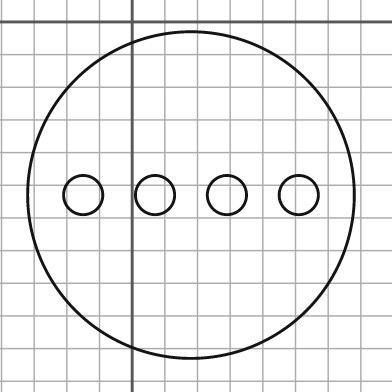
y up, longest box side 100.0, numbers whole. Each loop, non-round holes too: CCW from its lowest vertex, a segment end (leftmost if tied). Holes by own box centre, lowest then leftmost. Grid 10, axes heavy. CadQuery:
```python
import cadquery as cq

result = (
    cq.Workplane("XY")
    .moveTo(18.0, -53.0)
    .circle(50.0)
    .moveTo(-15.0, -53.0)
    .circle(6.0)
    .moveTo(7.0, -53.0)
    .circle(6.0)
    .moveTo(29.0, -53.0)
    .circle(6.0)
    .moveTo(51.0, -53.0)
    .circle(6.0)
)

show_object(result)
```